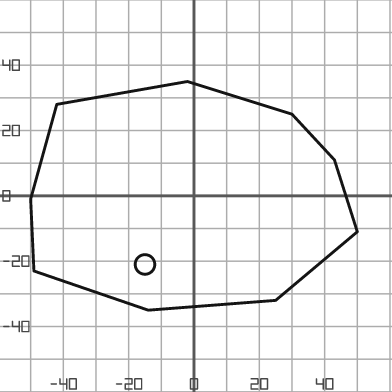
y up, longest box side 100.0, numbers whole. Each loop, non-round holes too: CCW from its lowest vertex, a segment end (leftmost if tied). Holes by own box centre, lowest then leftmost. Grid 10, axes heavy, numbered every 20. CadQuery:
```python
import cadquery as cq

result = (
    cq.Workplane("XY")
    .moveTo(-14.0, -35.0)
    .lineTo(25.0, -32.0)
    .lineTo(50.0, -11.0)
    .lineTo(43.0, 11.0)
    .lineTo(30.0, 25.0)
    .lineTo(-2.0, 35.0)
    .lineTo(-42.0, 28.0)
    .lineTo(-50.0, -1.0)
    .lineTo(-49.0, -23.0)
    .close()
    .moveTo(-15.0, -21.0)
    .circle(3.0)
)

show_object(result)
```